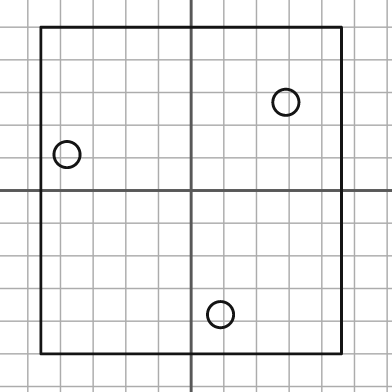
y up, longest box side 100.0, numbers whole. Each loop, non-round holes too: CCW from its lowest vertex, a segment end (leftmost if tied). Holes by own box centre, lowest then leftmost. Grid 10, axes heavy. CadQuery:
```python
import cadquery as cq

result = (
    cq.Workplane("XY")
    .moveTo(-46.0, -50.0)
    .lineTo(46.0, -50.0)
    .lineTo(46.0, 50.0)
    .lineTo(-46.0, 50.0)
    .close()
    .moveTo(9.0, -38.0)
    .circle(4.0)
    .moveTo(-38.0, 11.0)
    .circle(4.0)
    .moveTo(29.0, 27.0)
    .circle(4.0)
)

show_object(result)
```